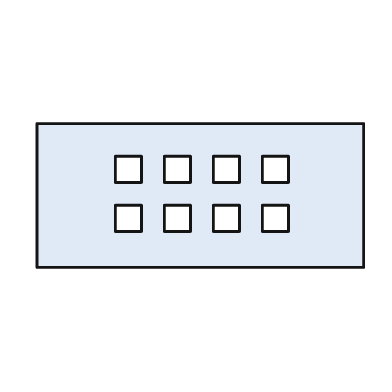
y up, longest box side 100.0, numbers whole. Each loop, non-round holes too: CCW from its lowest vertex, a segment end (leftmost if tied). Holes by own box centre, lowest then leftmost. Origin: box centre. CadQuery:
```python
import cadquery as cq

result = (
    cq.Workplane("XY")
    .moveTo(-50.0, -22.0)
    .lineTo(50.0, -22.0)
    .lineTo(50.0, 22.0)
    .lineTo(-50.0, 22.0)
    .close()
    .moveTo(-26.0, -11.0)
    .lineTo(-18.0, -11.0)
    .lineTo(-18.0, -3.0)
    .lineTo(-26.0, -3.0)
    .close()
    .moveTo(-11.0, -11.0)
    .lineTo(-3.0, -11.0)
    .lineTo(-3.0, -3.0)
    .lineTo(-11.0, -3.0)
    .close()
    .moveTo(4.0, -11.0)
    .lineTo(12.0, -11.0)
    .lineTo(12.0, -3.0)
    .lineTo(4.0, -3.0)
    .close()
    .moveTo(19.0, -11.0)
    .lineTo(27.0, -11.0)
    .lineTo(27.0, -3.0)
    .lineTo(19.0, -3.0)
    .close()
    .moveTo(-26.0, 4.0)
    .lineTo(-18.0, 4.0)
    .lineTo(-18.0, 12.0)
    .lineTo(-26.0, 12.0)
    .close()
    .moveTo(-11.0, 4.0)
    .lineTo(-3.0, 4.0)
    .lineTo(-3.0, 12.0)
    .lineTo(-11.0, 12.0)
    .close()
    .moveTo(4.0, 4.0)
    .lineTo(12.0, 4.0)
    .lineTo(12.0, 12.0)
    .lineTo(4.0, 12.0)
    .close()
    .moveTo(19.0, 4.0)
    .lineTo(27.0, 4.0)
    .lineTo(27.0, 12.0)
    .lineTo(19.0, 12.0)
    .close()
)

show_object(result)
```